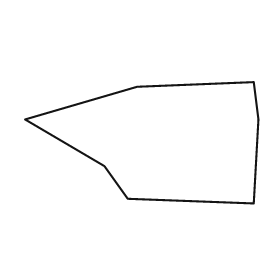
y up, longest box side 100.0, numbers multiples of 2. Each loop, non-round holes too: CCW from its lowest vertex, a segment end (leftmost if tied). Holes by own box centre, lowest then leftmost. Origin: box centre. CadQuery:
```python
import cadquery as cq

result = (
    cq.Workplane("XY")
    .moveTo(48.0, -26.0)
    .lineTo(50.0, 10.0)
    .lineTo(48.0, 26.0)
    .lineTo(-2.0, 24.0)
    .lineTo(-50.0, 10.0)
    .lineTo(-16.0, -10.0)
    .lineTo(-6.0, -24.0)
    .close()
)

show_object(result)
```